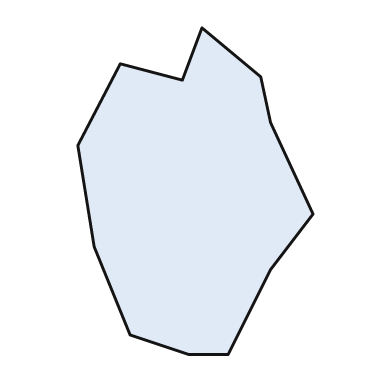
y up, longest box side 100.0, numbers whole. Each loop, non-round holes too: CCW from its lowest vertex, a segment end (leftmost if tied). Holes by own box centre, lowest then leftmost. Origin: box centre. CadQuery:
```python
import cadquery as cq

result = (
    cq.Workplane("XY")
    .moveTo(-2.0, -50.0)
    .lineTo(10.0, -50.0)
    .lineTo(23.0, -24.0)
    .lineTo(36.0, -7.0)
    .lineTo(23.0, 21.0)
    .lineTo(20.0, 35.0)
    .lineTo(2.0, 50.0)
    .lineTo(-4.0, 34.0)
    .lineTo(-23.0, 39.0)
    .lineTo(-36.0, 14.0)
    .lineTo(-31.0, -17.0)
    .lineTo(-20.0, -44.0)
    .close()
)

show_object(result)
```